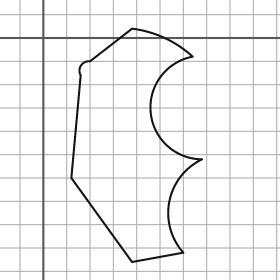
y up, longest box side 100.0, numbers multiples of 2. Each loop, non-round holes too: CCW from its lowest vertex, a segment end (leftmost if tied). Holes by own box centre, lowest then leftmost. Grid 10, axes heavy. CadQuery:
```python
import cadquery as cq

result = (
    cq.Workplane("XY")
    .moveTo(38.0, -96.0)
    .lineTo(60.0, -92.0)
    .threePointArc((54.0, -70.0), (68.0, -52.0))
    .threePointArc((46.0, -32.0), (64.0, -8.0))
    .threePointArc((52.0, 0.0), (38.0, 4.0))
    .lineTo(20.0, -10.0)
    .threePointArc((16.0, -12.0), (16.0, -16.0))
    .lineTo(12.0, -60.0)
    .close()
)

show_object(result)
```